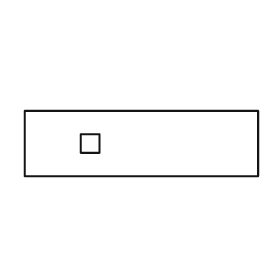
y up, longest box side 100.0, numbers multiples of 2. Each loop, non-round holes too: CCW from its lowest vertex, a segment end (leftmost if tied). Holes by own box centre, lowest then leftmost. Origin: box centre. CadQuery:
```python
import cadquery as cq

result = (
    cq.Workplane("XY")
    .moveTo(-50.0, -14.0)
    .lineTo(50.0, -14.0)
    .lineTo(50.0, 14.0)
    .lineTo(-50.0, 14.0)
    .close()
    .moveTo(-26.0, -4.0)
    .lineTo(-18.0, -4.0)
    .lineTo(-18.0, 4.0)
    .lineTo(-26.0, 4.0)
    .close()
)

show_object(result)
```